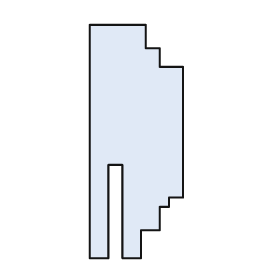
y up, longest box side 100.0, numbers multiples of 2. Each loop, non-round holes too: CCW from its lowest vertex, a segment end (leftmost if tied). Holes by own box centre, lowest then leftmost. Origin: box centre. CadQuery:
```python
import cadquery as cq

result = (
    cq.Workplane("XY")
    .moveTo(-20.0, -50.0)
    .lineTo(-12.0, -50.0)
    .lineTo(-12.0, -10.0)
    .lineTo(-6.0, -10.0)
    .lineTo(-6.0, -50.0)
    .lineTo(2.0, -50.0)
    .lineTo(2.0, -38.0)
    .lineTo(10.0, -38.0)
    .lineTo(10.0, -28.0)
    .lineTo(14.0, -28.0)
    .lineTo(14.0, -24.0)
    .lineTo(20.0, -24.0)
    .lineTo(20.0, 32.0)
    .lineTo(10.0, 32.0)
    .lineTo(10.0, 40.0)
    .lineTo(4.0, 40.0)
    .lineTo(4.0, 50.0)
    .lineTo(-20.0, 50.0)
    .close()
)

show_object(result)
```